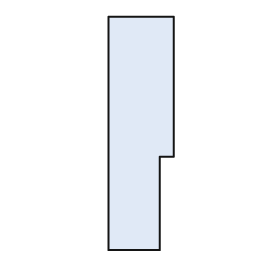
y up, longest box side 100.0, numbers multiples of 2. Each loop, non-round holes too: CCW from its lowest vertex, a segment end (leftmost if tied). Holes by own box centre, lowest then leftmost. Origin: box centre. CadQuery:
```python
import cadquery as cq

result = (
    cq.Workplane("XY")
    .moveTo(-14.0, -50.0)
    .lineTo(8.0, -50.0)
    .lineTo(8.0, -10.0)
    .lineTo(14.0, -10.0)
    .lineTo(14.0, 50.0)
    .lineTo(-14.0, 50.0)
    .close()
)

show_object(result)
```